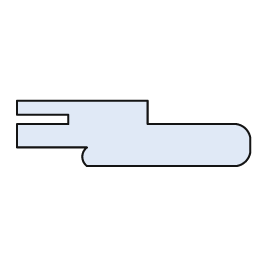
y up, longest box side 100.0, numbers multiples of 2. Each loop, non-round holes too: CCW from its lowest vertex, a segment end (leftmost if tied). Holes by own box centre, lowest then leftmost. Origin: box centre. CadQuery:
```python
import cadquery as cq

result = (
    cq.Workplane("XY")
    .moveTo(-20.0, -14.0)
    .lineTo(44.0, -14.0)
    .threePointArc((48.0, -12.0), (50.0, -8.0))
    .lineTo(50.0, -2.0)
    .threePointArc((48.0, 2.0), (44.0, 4.0))
    .lineTo(6.0, 4.0)
    .lineTo(6.0, 14.0)
    .lineTo(-50.0, 14.0)
    .lineTo(-50.0, 8.0)
    .lineTo(-28.0, 8.0)
    .lineTo(-28.0, 4.0)
    .lineTo(-50.0, 4.0)
    .lineTo(-50.0, -6.0)
    .lineTo(-20.0, -6.0)
    .threePointArc((-22.0, -10.0), (-20.0, -14.0))
    .close()
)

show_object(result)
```